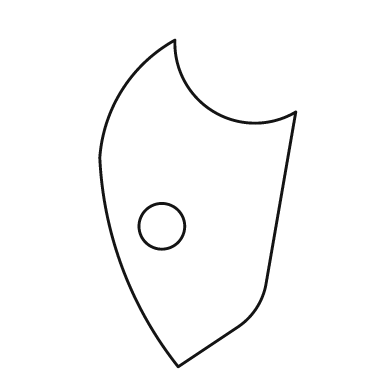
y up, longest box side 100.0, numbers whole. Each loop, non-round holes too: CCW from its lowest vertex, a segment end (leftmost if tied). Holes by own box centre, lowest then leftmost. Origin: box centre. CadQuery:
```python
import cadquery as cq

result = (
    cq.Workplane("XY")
    .moveTo(-6.0, -50.0)
    .lineTo(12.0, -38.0)
    .threePointArc((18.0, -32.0), (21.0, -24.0))
    .lineTo(30.0, 28.0)
    .threePointArc((5.0, 28.0), (-7.0, 50.0))
    .threePointArc((-23.0, 35.0), (-30.0, 14.0))
    .threePointArc((-23.0, -20.0), (-6.0, -50.0))
    .close()
    .moveTo(-11.0, -7.0)
    .circle(7.0)
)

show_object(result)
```